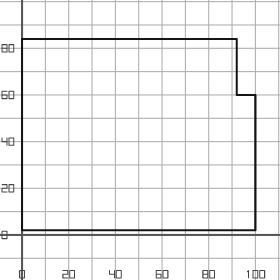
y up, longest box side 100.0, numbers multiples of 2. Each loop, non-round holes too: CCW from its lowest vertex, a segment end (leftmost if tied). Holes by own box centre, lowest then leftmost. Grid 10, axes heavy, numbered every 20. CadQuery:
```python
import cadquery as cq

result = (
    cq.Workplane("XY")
    .moveTo(0.0, 2.0)
    .lineTo(100.0, 2.0)
    .lineTo(100.0, 60.0)
    .lineTo(92.0, 60.0)
    .lineTo(92.0, 84.0)
    .lineTo(0.0, 84.0)
    .close()
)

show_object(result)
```